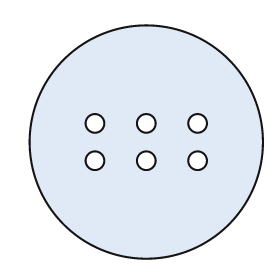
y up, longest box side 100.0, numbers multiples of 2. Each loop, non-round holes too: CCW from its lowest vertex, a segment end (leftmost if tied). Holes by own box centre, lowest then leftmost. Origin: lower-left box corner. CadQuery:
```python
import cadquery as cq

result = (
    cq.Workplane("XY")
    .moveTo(50.0, 50.0)
    .circle(50.0)
    .moveTo(28.0, 42.0)
    .circle(4.0)
    .moveTo(50.0, 42.0)
    .circle(4.0)
    .moveTo(72.0, 42.0)
    .circle(4.0)
    .moveTo(28.0, 58.0)
    .circle(4.0)
    .moveTo(50.0, 58.0)
    .circle(4.0)
    .moveTo(72.0, 58.0)
    .circle(4.0)
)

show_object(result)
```